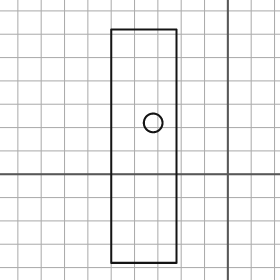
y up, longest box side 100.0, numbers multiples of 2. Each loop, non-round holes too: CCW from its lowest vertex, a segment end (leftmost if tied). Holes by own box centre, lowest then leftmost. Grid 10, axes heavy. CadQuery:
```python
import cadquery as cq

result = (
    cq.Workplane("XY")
    .moveTo(-50.0, -38.0)
    .lineTo(-22.0, -38.0)
    .lineTo(-22.0, 62.0)
    .lineTo(-50.0, 62.0)
    .close()
    .moveTo(-32.0, 22.0)
    .circle(4.0)
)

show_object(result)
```